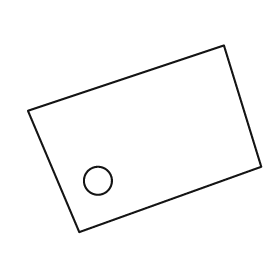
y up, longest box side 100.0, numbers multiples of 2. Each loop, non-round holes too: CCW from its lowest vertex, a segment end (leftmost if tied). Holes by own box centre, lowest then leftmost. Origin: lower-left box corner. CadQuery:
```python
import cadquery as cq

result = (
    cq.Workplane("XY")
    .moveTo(22.0, 0.0)
    .lineTo(100.0, 28.0)
    .lineTo(84.0, 80.0)
    .lineTo(0.0, 52.0)
    .close()
    .moveTo(30.0, 22.0)
    .circle(6.0)
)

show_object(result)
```